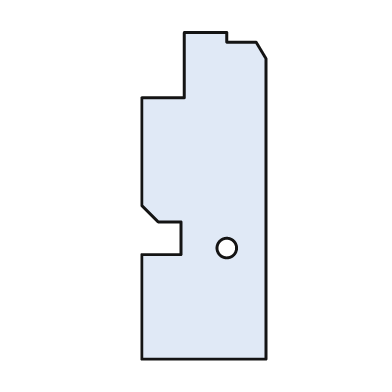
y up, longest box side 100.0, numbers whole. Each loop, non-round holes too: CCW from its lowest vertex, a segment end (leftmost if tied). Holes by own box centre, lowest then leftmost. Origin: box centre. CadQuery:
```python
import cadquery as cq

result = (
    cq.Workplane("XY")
    .moveTo(-19.0, -50.0)
    .lineTo(19.0, -50.0)
    .lineTo(19.0, 42.0)
    .lineTo(16.0, 47.0)
    .lineTo(7.0, 47.0)
    .lineTo(7.0, 50.0)
    .lineTo(-6.0, 50.0)
    .lineTo(-6.0, 30.0)
    .lineTo(-19.0, 30.0)
    .lineTo(-19.0, -3.0)
    .lineTo(-14.0, -8.0)
    .lineTo(-7.0, -8.0)
    .lineTo(-7.0, -18.0)
    .lineTo(-19.0, -18.0)
    .close()
    .moveTo(7.0, -16.0)
    .circle(3.0)
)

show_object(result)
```